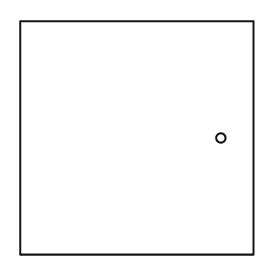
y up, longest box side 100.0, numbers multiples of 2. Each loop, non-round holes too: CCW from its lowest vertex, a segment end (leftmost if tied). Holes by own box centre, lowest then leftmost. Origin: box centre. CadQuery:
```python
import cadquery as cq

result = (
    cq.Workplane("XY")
    .moveTo(-50.0, -50.0)
    .lineTo(50.0, -50.0)
    .lineTo(50.0, 50.0)
    .lineTo(-50.0, 50.0)
    .close()
    .moveTo(36.0, 0.0)
    .circle(2.0)
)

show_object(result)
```